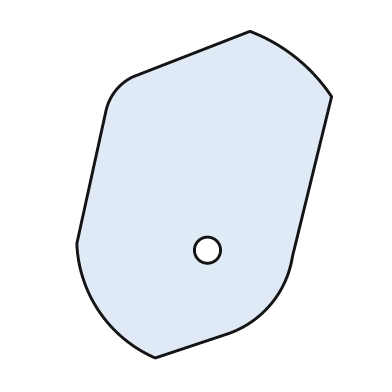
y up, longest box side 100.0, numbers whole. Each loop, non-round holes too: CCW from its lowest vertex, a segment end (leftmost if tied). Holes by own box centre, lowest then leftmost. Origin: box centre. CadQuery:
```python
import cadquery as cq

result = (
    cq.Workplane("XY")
    .moveTo(-15.0, -50.0)
    .lineTo(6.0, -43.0)
    .threePointArc((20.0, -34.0), (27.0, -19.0))
    .lineTo(39.0, 30.0)
    .threePointArc((28.0, 42.0), (14.0, 50.0))
    .lineTo(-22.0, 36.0)
    .threePointArc((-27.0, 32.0), (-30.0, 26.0))
    .lineTo(-39.0, -15.0)
    .threePointArc((-32.0, -36.0), (-15.0, -50.0))
    .close()
    .moveTo(1.0, -17.0)
    .circle(4.0)
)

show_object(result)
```